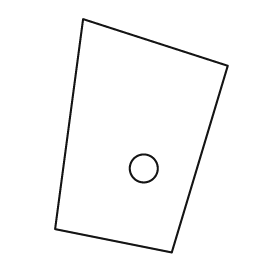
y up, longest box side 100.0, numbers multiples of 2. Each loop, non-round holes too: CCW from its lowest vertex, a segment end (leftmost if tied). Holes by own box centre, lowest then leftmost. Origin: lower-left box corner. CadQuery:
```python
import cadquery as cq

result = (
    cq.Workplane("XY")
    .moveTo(50.0, 0.0)
    .lineTo(74.0, 80.0)
    .lineTo(12.0, 100.0)
    .lineTo(0.0, 10.0)
    .close()
    .moveTo(38.0, 36.0)
    .circle(6.0)
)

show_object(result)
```